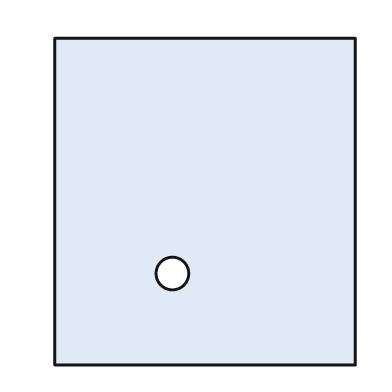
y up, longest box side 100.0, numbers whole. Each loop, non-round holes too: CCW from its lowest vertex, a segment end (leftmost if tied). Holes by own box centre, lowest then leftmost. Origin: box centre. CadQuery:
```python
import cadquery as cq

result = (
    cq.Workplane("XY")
    .moveTo(-46.0, -50.0)
    .lineTo(46.0, -50.0)
    .lineTo(46.0, 50.0)
    .lineTo(-46.0, 50.0)
    .close()
    .moveTo(-10.0, -22.0)
    .circle(5.0)
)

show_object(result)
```